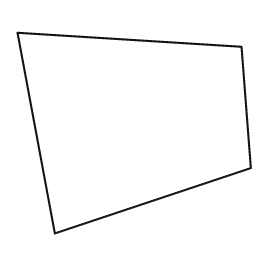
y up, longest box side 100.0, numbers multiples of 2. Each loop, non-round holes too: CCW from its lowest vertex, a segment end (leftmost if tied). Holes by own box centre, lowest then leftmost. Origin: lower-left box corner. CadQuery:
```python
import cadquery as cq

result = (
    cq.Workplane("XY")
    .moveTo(16.0, 0.0)
    .lineTo(100.0, 28.0)
    .lineTo(96.0, 80.0)
    .lineTo(0.0, 86.0)
    .close()
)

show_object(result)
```